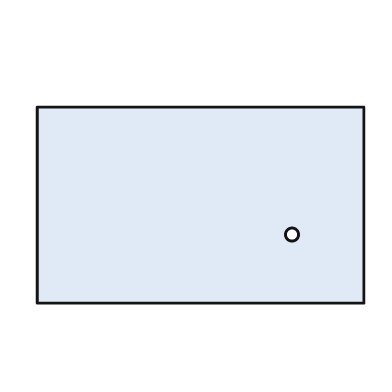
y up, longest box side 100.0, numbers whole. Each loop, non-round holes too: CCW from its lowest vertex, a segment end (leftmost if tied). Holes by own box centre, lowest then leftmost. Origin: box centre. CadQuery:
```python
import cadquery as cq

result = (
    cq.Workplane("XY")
    .moveTo(-50.0, -30.0)
    .lineTo(50.0, -30.0)
    .lineTo(50.0, 30.0)
    .lineTo(-50.0, 30.0)
    .close()
    .moveTo(28.0, -9.0)
    .circle(2.0)
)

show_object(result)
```